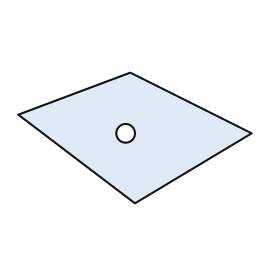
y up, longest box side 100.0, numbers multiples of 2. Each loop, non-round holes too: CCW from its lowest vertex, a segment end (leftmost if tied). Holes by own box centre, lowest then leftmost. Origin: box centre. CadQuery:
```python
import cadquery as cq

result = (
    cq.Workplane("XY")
    .moveTo(0.0, -28.0)
    .lineTo(50.0, 2.0)
    .lineTo(-2.0, 28.0)
    .lineTo(-50.0, 10.0)
    .close()
    .moveTo(-4.0, 2.0)
    .circle(4.0)
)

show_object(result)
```